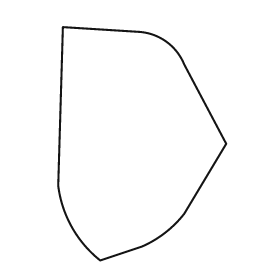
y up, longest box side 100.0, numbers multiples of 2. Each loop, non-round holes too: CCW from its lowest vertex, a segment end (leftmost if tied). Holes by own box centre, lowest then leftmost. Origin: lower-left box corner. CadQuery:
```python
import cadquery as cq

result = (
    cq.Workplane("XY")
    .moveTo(18.0, 0.0)
    .lineTo(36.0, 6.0)
    .threePointArc((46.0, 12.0), (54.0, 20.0))
    .lineTo(72.0, 50.0)
    .lineTo(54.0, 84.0)
    .threePointArc((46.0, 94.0), (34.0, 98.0))
    .lineTo(2.0, 100.0)
    .lineTo(0.0, 32.0)
    .threePointArc((6.0, 14.0), (18.0, 0.0))
    .close()
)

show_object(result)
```